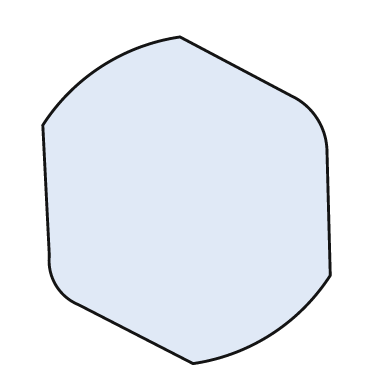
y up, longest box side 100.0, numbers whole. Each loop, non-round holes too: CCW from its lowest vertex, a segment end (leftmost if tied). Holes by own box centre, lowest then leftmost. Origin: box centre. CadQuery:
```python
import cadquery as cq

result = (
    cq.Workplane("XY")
    .moveTo(2.0, -50.0)
    .threePointArc((26.0, -41.0), (44.0, -23.0))
    .lineTo(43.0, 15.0)
    .threePointArc((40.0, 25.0), (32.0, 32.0))
    .lineTo(-2.0, 50.0)
    .threePointArc((-26.0, 41.0), (-44.0, 23.0))
    .lineTo(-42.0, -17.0)
    .threePointArc((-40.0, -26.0), (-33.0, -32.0))
    .close()
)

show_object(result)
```